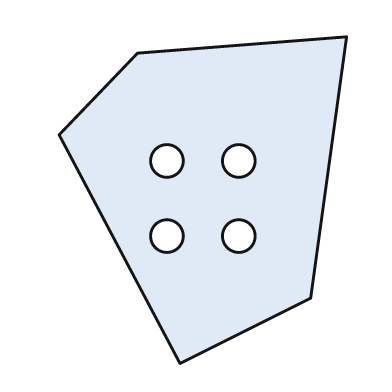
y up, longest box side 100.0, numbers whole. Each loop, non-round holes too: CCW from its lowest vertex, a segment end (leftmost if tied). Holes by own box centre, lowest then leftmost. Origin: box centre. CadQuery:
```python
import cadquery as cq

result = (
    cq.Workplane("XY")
    .moveTo(-7.0, -50.0)
    .lineTo(33.0, -30.0)
    .lineTo(44.0, 50.0)
    .lineTo(-20.0, 45.0)
    .lineTo(-44.0, 20.0)
    .close()
    .moveTo(-11.0, -11.0)
    .circle(5.0)
    .moveTo(11.0, -11.0)
    .circle(5.0)
    .moveTo(-11.0, 12.0)
    .circle(5.0)
    .moveTo(11.0, 12.0)
    .circle(5.0)
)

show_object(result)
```